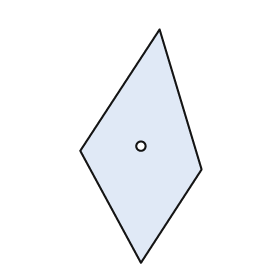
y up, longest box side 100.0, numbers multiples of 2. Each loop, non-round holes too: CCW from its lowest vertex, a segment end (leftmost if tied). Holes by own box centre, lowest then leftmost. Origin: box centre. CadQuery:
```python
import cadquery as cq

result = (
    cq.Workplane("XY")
    .moveTo(0.0, -50.0)
    .lineTo(26.0, -10.0)
    .lineTo(8.0, 50.0)
    .lineTo(-26.0, -2.0)
    .close()
    .moveTo(0.0, 0.0)
    .circle(2.0)
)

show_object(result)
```